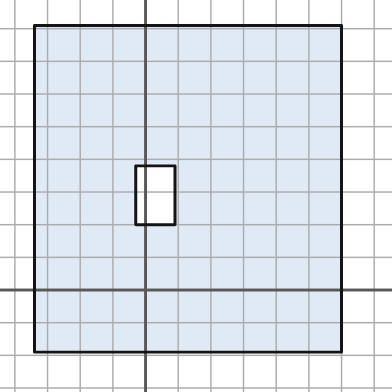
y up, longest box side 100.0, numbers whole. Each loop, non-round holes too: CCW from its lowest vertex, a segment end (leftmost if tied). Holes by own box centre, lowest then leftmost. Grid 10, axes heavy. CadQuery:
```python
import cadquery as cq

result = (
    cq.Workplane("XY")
    .moveTo(-34.0, -19.0)
    .lineTo(60.0, -19.0)
    .lineTo(60.0, 81.0)
    .lineTo(-34.0, 81.0)
    .close()
    .moveTo(-3.0, 20.0)
    .lineTo(9.0, 20.0)
    .lineTo(9.0, 38.0)
    .lineTo(-3.0, 38.0)
    .close()
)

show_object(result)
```